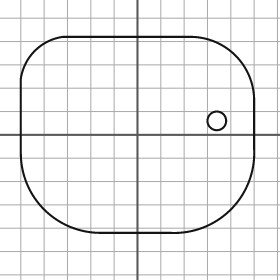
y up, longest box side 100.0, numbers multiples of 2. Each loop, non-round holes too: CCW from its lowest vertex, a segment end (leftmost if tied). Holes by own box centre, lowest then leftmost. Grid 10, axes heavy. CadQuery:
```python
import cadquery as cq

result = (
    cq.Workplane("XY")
    .moveTo(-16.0, -42.0)
    .lineTo(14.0, -42.0)
    .threePointArc((40.0, -32.0), (50.0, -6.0))
    .lineTo(50.0, 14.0)
    .threePointArc((42.0, 34.0), (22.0, 42.0))
    .lineTo(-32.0, 42.0)
    .threePointArc((-44.0, 36.0), (-50.0, 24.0))
    .lineTo(-50.0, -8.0)
    .threePointArc((-40.0, -32.0), (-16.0, -42.0))
    .close()
    .moveTo(34.0, 6.0)
    .circle(4.0)
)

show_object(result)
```